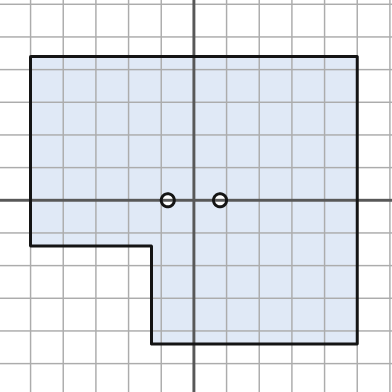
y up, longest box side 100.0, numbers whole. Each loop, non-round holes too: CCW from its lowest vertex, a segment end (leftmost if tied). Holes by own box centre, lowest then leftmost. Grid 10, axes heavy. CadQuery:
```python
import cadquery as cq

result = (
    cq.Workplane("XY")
    .moveTo(-13.0, -44.0)
    .lineTo(50.0, -44.0)
    .lineTo(50.0, 44.0)
    .lineTo(-50.0, 44.0)
    .lineTo(-50.0, -14.0)
    .lineTo(-13.0, -14.0)
    .close()
    .moveTo(-8.0, 0.0)
    .circle(2.0)
    .moveTo(8.0, 0.0)
    .circle(2.0)
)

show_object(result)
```